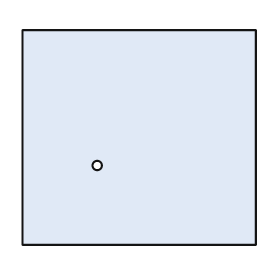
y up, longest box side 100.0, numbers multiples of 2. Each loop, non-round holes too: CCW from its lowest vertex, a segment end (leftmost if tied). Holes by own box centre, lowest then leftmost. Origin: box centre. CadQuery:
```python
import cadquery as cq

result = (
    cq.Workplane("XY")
    .moveTo(-50.0, -46.0)
    .lineTo(50.0, -46.0)
    .lineTo(50.0, 46.0)
    .lineTo(-50.0, 46.0)
    .close()
    .moveTo(-18.0, -12.0)
    .circle(2.0)
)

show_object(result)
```